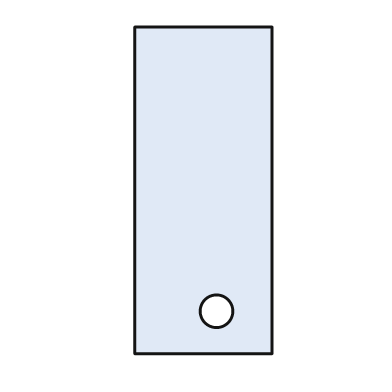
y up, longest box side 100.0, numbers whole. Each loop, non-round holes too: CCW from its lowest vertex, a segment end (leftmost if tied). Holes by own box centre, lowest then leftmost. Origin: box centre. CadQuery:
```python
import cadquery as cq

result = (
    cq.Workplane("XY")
    .moveTo(-21.0, -50.0)
    .lineTo(21.0, -50.0)
    .lineTo(21.0, 50.0)
    .lineTo(-21.0, 50.0)
    .close()
    .moveTo(4.0, -37.0)
    .circle(5.0)
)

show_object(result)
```